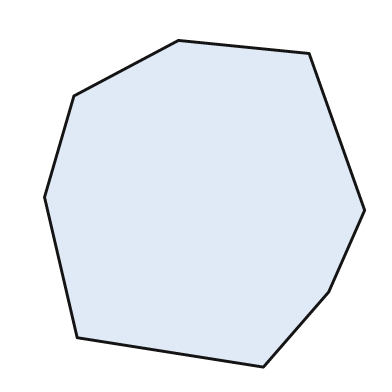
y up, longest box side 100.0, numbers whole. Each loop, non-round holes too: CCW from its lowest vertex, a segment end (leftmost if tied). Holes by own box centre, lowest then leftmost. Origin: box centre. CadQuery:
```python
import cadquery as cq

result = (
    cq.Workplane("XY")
    .moveTo(18.0, -50.0)
    .lineTo(38.0, -27.0)
    .lineTo(49.0, -2.0)
    .lineTo(32.0, 46.0)
    .lineTo(-8.0, 50.0)
    .lineTo(-40.0, 33.0)
    .lineTo(-49.0, 2.0)
    .lineTo(-39.0, -41.0)
    .close()
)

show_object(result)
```